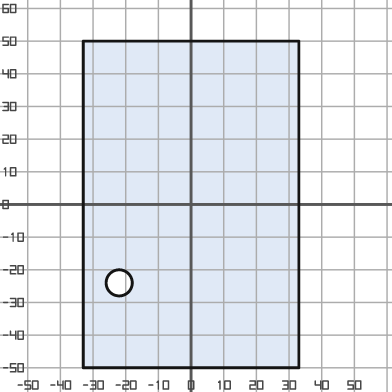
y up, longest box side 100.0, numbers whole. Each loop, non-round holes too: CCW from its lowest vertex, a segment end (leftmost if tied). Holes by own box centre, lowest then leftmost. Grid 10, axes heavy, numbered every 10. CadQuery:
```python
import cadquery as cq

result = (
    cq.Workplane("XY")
    .moveTo(-33.0, -50.0)
    .lineTo(33.0, -50.0)
    .lineTo(33.0, 50.0)
    .lineTo(-33.0, 50.0)
    .close()
    .moveTo(-22.0, -24.0)
    .circle(4.0)
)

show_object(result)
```